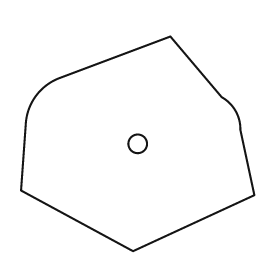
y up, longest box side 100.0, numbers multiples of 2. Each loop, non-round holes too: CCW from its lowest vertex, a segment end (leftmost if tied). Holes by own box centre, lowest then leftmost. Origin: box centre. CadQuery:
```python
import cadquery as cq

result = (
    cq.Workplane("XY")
    .moveTo(-2.0, -46.0)
    .lineTo(50.0, -22.0)
    .lineTo(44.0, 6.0)
    .threePointArc((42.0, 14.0), (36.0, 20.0))
    .lineTo(14.0, 46.0)
    .lineTo(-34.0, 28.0)
    .threePointArc((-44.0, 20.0), (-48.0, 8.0))
    .lineTo(-50.0, -20.0)
    .close()
    .moveTo(0.0, 0.0)
    .circle(4.0)
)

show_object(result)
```